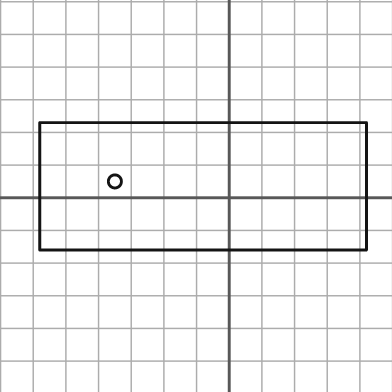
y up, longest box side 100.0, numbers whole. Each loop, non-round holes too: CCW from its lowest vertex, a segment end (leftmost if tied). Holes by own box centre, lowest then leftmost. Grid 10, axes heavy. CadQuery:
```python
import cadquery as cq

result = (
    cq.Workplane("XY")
    .moveTo(-58.0, -16.0)
    .lineTo(42.0, -16.0)
    .lineTo(42.0, 23.0)
    .lineTo(-58.0, 23.0)
    .close()
    .moveTo(-35.0, 5.0)
    .circle(2.0)
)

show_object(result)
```